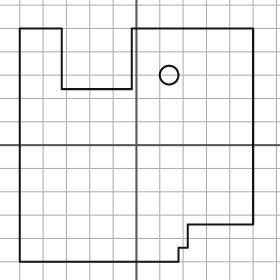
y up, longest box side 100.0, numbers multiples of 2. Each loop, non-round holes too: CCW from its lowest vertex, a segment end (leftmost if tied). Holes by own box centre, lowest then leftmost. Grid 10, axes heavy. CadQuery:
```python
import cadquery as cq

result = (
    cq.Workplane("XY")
    .moveTo(-50.0, -50.0)
    .lineTo(18.0, -50.0)
    .lineTo(18.0, -44.0)
    .lineTo(22.0, -44.0)
    .lineTo(22.0, -34.0)
    .lineTo(50.0, -34.0)
    .lineTo(50.0, 50.0)
    .lineTo(-2.0, 50.0)
    .lineTo(-2.0, 24.0)
    .lineTo(-32.0, 24.0)
    .lineTo(-32.0, 50.0)
    .lineTo(-50.0, 50.0)
    .close()
    .moveTo(14.0, 30.0)
    .circle(4.0)
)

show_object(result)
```